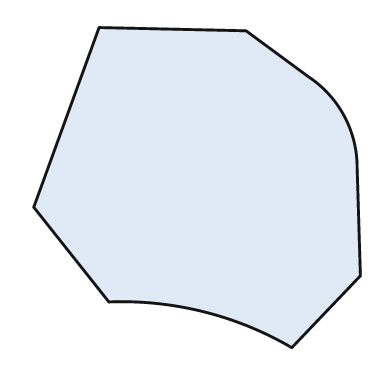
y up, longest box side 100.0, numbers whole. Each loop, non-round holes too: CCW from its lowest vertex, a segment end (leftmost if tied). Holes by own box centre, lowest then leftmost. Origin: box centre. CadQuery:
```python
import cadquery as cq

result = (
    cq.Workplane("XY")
    .moveTo(29.0, -49.0)
    .lineTo(50.0, -27.0)
    .lineTo(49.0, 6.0)
    .threePointArc((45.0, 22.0), (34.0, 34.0))
    .lineTo(15.0, 48.0)
    .lineTo(-30.0, 49.0)
    .lineTo(-50.0, -6.0)
    .lineTo(-27.0, -35.0)
    .threePointArc((2.0, -38.0), (29.0, -49.0))
    .close()
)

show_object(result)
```